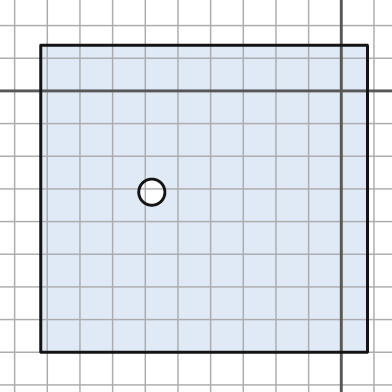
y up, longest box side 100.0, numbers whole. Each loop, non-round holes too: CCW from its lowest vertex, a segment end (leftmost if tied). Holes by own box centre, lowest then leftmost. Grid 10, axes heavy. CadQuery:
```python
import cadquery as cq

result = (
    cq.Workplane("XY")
    .moveTo(-92.0, -80.0)
    .lineTo(8.0, -80.0)
    .lineTo(8.0, 14.0)
    .lineTo(-92.0, 14.0)
    .close()
    .moveTo(-58.0, -31.0)
    .circle(4.0)
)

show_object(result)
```